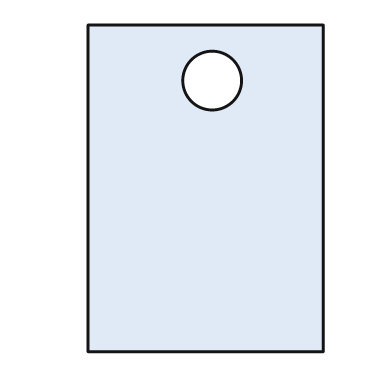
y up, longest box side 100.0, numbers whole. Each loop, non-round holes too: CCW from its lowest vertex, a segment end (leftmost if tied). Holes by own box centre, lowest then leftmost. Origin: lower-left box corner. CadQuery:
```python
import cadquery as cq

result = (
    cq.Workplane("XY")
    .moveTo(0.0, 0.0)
    .lineTo(72.0, 0.0)
    .lineTo(72.0, 100.0)
    .lineTo(0.0, 100.0)
    .close()
    .moveTo(38.0, 83.0)
    .circle(9.0)
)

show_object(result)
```